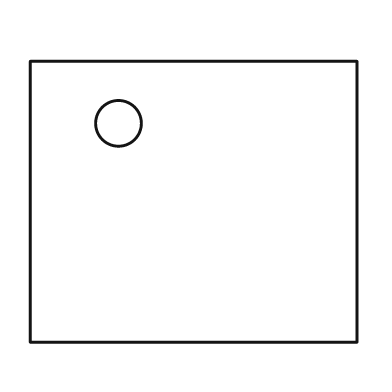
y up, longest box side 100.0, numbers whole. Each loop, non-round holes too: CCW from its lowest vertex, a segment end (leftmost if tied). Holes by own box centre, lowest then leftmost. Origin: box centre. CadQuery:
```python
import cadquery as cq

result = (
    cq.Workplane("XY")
    .moveTo(-50.0, -43.0)
    .lineTo(50.0, -43.0)
    .lineTo(50.0, 43.0)
    .lineTo(-50.0, 43.0)
    .close()
    .moveTo(-23.0, 24.0)
    .circle(7.0)
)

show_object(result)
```